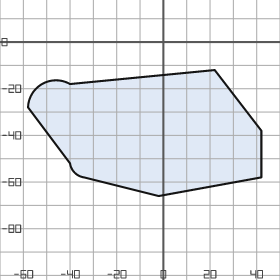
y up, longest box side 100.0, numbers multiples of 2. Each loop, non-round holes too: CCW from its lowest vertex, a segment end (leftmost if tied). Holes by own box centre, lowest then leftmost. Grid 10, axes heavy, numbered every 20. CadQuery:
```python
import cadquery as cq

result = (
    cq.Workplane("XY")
    .moveTo(-2.0, -66.0)
    .lineTo(42.0, -58.0)
    .lineTo(42.0, -38.0)
    .lineTo(22.0, -12.0)
    .lineTo(-40.0, -18.0)
    .threePointArc((-52.0, -18.0), (-58.0, -28.0))
    .lineTo(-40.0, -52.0)
    .threePointArc((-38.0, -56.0), (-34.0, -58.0))
    .close()
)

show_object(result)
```